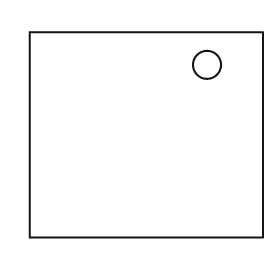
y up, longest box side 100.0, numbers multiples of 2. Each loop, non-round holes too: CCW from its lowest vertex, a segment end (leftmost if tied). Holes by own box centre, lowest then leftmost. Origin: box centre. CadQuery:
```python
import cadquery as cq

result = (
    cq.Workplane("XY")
    .moveTo(-50.0, -44.0)
    .lineTo(50.0, -44.0)
    .lineTo(50.0, 44.0)
    .lineTo(-50.0, 44.0)
    .close()
    .moveTo(26.0, 30.0)
    .circle(6.0)
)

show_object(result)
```